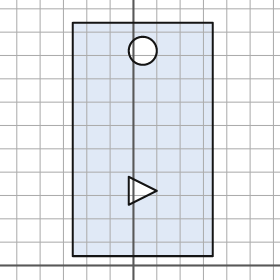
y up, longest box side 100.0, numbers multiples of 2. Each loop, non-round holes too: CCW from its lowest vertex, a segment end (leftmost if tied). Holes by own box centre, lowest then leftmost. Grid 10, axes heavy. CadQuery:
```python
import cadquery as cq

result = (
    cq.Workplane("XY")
    .moveTo(-26.0, 4.0)
    .lineTo(34.0, 4.0)
    .lineTo(34.0, 104.0)
    .lineTo(-26.0, 104.0)
    .close()
    .moveTo(-2.0, 26.0)
    .lineTo(10.0, 32.0)
    .lineTo(-2.0, 38.0)
    .close()
    .moveTo(4.0, 92.0)
    .circle(6.0)
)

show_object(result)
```